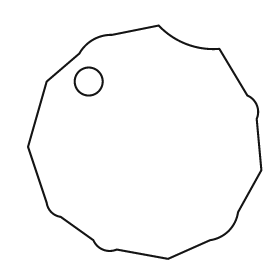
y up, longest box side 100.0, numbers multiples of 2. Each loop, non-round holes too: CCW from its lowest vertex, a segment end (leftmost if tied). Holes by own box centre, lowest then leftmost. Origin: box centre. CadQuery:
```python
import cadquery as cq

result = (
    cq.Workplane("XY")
    .moveTo(10.0, -50.0)
    .lineTo(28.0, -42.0)
    .threePointArc((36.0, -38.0), (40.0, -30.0))
    .lineTo(50.0, -12.0)
    .lineTo(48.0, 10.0)
    .threePointArc((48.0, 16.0), (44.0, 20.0))
    .lineTo(32.0, 40.0)
    .threePointArc((18.0, 42.0), (6.0, 50.0))
    .lineTo(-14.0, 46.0)
    .threePointArc((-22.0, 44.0), (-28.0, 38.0))
    .lineTo(-42.0, 26.0)
    .lineTo(-50.0, -2.0)
    .lineTo(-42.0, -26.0)
    .threePointArc((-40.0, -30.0), (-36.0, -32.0))
    .lineTo(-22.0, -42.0)
    .threePointArc((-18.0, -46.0), (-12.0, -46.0))
    .close()
    .moveTo(-24.0, 26.0)
    .circle(6.0)
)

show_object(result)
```